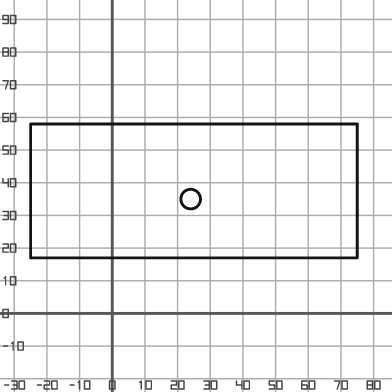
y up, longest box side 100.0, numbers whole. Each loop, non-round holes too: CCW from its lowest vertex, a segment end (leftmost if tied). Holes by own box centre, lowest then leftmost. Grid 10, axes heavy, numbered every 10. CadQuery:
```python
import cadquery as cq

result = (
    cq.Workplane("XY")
    .moveTo(-25.0, 17.0)
    .lineTo(75.0, 17.0)
    .lineTo(75.0, 58.0)
    .lineTo(-25.0, 58.0)
    .close()
    .moveTo(24.0, 35.0)
    .circle(3.0)
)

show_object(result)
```